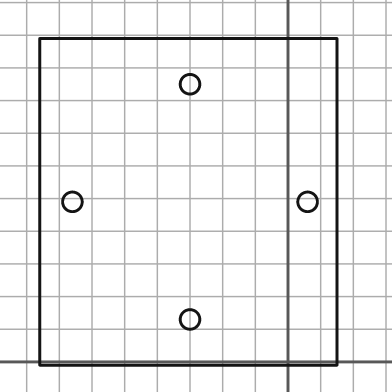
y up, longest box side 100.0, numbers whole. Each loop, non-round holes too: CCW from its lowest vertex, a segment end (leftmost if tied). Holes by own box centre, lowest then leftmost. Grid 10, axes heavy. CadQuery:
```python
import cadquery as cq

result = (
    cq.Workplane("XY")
    .moveTo(-76.0, -1.0)
    .lineTo(15.0, -1.0)
    .lineTo(15.0, 99.0)
    .lineTo(-76.0, 99.0)
    .close()
    .moveTo(-30.0, 13.0)
    .circle(3.0)
    .moveTo(-66.0, 49.0)
    .circle(3.0)
    .moveTo(6.0, 49.0)
    .circle(3.0)
    .moveTo(-30.0, 85.0)
    .circle(3.0)
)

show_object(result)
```